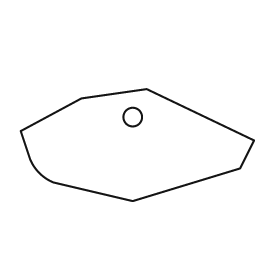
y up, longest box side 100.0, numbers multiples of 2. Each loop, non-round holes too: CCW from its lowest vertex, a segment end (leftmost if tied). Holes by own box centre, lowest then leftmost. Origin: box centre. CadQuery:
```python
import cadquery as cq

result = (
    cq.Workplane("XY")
    .moveTo(-2.0, -24.0)
    .lineTo(44.0, -10.0)
    .lineTo(50.0, 2.0)
    .lineTo(4.0, 24.0)
    .lineTo(-24.0, 20.0)
    .lineTo(-50.0, 6.0)
    .lineTo(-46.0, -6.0)
    .threePointArc((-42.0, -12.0), (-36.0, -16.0))
    .close()
    .moveTo(-2.0, 12.0)
    .circle(4.0)
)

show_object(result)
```